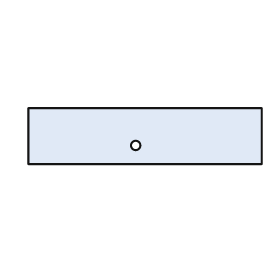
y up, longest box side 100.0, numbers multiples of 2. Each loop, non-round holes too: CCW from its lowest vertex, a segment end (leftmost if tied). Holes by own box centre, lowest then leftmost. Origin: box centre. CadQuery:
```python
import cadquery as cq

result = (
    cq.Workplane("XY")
    .moveTo(-50.0, -12.0)
    .lineTo(50.0, -12.0)
    .lineTo(50.0, 12.0)
    .lineTo(-50.0, 12.0)
    .close()
    .moveTo(-4.0, -4.0)
    .circle(2.0)
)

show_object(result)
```